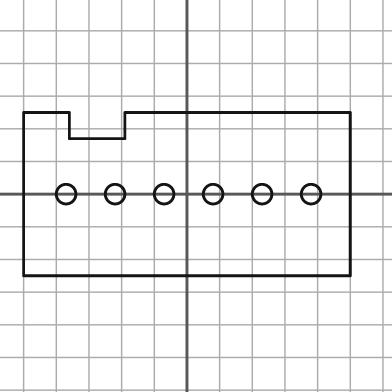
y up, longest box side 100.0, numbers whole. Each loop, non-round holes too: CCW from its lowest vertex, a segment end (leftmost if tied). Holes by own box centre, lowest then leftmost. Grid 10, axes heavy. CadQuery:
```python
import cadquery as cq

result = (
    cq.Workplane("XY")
    .moveTo(-50.0, -25.0)
    .lineTo(50.0, -25.0)
    .lineTo(50.0, 25.0)
    .lineTo(-19.0, 25.0)
    .lineTo(-19.0, 17.0)
    .lineTo(-36.0, 17.0)
    .lineTo(-36.0, 25.0)
    .lineTo(-50.0, 25.0)
    .close()
    .moveTo(-37.0, 0.0)
    .circle(3.0)
    .moveTo(-22.0, 0.0)
    .circle(3.0)
    .moveTo(-7.0, 0.0)
    .circle(3.0)
    .moveTo(8.0, 0.0)
    .circle(3.0)
    .moveTo(23.0, 0.0)
    .circle(3.0)
    .moveTo(38.0, 0.0)
    .circle(3.0)
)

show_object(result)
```